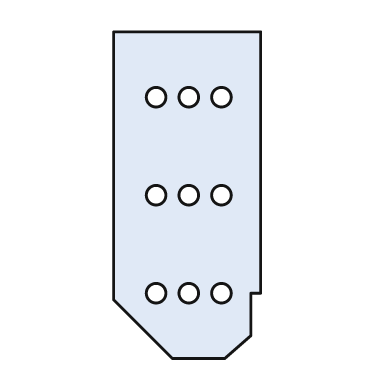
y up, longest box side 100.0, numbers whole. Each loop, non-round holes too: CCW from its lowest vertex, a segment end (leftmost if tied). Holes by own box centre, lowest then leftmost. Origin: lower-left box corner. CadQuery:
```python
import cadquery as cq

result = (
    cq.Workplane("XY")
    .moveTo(18.0, 0.0)
    .lineTo(34.0, 0.0)
    .lineTo(42.0, 7.0)
    .lineTo(42.0, 20.0)
    .lineTo(45.0, 20.0)
    .lineTo(45.0, 100.0)
    .lineTo(0.0, 100.0)
    .lineTo(0.0, 18.0)
    .close()
    .moveTo(13.0, 20.0)
    .circle(3.0)
    .moveTo(23.0, 20.0)
    .circle(3.0)
    .moveTo(33.0, 20.0)
    .circle(3.0)
    .moveTo(13.0, 50.0)
    .circle(3.0)
    .moveTo(23.0, 50.0)
    .circle(3.0)
    .moveTo(33.0, 50.0)
    .circle(3.0)
    .moveTo(13.0, 80.0)
    .circle(3.0)
    .moveTo(23.0, 80.0)
    .circle(3.0)
    .moveTo(33.0, 80.0)
    .circle(3.0)
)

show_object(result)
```